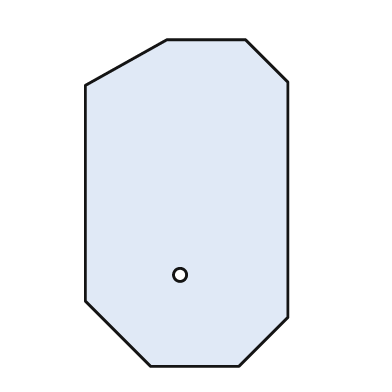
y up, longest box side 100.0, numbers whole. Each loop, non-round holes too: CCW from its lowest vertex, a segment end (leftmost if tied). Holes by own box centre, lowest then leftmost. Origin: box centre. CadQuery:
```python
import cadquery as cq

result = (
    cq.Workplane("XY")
    .moveTo(-11.0, -50.0)
    .lineTo(16.0, -50.0)
    .lineTo(31.0, -35.0)
    .lineTo(31.0, 37.0)
    .lineTo(18.0, 50.0)
    .lineTo(-6.0, 50.0)
    .lineTo(-31.0, 36.0)
    .lineTo(-31.0, -30.0)
    .close()
    .moveTo(-2.0, -22.0)
    .circle(2.0)
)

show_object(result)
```